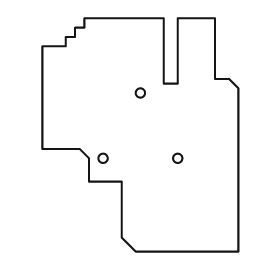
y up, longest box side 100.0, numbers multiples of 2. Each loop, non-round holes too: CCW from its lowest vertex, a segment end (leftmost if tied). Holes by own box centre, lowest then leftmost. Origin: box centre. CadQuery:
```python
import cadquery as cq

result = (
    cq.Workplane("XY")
    .moveTo(-2.0, -50.0)
    .lineTo(42.0, -50.0)
    .lineTo(42.0, 20.0)
    .lineTo(38.0, 24.0)
    .lineTo(32.0, 24.0)
    .lineTo(32.0, 50.0)
    .lineTo(16.0, 50.0)
    .lineTo(16.0, 22.0)
    .lineTo(10.0, 22.0)
    .lineTo(10.0, 50.0)
    .lineTo(-24.0, 50.0)
    .lineTo(-24.0, 46.0)
    .lineTo(-28.0, 46.0)
    .lineTo(-28.0, 42.0)
    .lineTo(-32.0, 42.0)
    .lineTo(-32.0, 38.0)
    .lineTo(-42.0, 38.0)
    .lineTo(-42.0, -6.0)
    .lineTo(-26.0, -6.0)
    .lineTo(-22.0, -10.0)
    .lineTo(-22.0, -20.0)
    .lineTo(-8.0, -20.0)
    .lineTo(-8.0, -44.0)
    .close()
    .moveTo(-16.0, -10.0)
    .circle(2.0)
    .moveTo(16.0, -10.0)
    .circle(2.0)
    .moveTo(0.0, 18.0)
    .circle(2.0)
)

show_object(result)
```